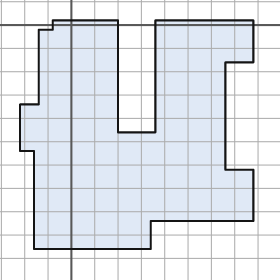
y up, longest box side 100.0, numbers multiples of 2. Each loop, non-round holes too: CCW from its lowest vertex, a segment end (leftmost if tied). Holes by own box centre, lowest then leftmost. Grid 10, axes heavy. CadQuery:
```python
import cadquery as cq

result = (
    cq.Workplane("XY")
    .moveTo(-16.0, -96.0)
    .lineTo(34.0, -96.0)
    .lineTo(34.0, -84.0)
    .lineTo(78.0, -84.0)
    .lineTo(78.0, -62.0)
    .lineTo(66.0, -62.0)
    .lineTo(66.0, -16.0)
    .lineTo(78.0, -16.0)
    .lineTo(78.0, 2.0)
    .lineTo(36.0, 2.0)
    .lineTo(36.0, -46.0)
    .lineTo(20.0, -46.0)
    .lineTo(20.0, 2.0)
    .lineTo(-8.0, 2.0)
    .lineTo(-8.0, -2.0)
    .lineTo(-14.0, -2.0)
    .lineTo(-14.0, -34.0)
    .lineTo(-22.0, -34.0)
    .lineTo(-22.0, -54.0)
    .lineTo(-16.0, -54.0)
    .close()
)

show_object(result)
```